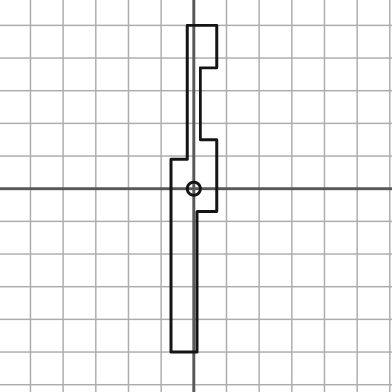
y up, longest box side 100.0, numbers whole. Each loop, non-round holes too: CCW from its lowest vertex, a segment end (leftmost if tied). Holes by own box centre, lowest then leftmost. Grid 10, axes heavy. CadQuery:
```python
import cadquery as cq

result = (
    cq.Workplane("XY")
    .moveTo(-7.0, -50.0)
    .lineTo(1.0, -50.0)
    .lineTo(1.0, -7.0)
    .lineTo(7.0, -7.0)
    .lineTo(7.0, 15.0)
    .lineTo(2.0, 15.0)
    .lineTo(2.0, 37.0)
    .lineTo(7.0, 37.0)
    .lineTo(7.0, 50.0)
    .lineTo(-2.0, 50.0)
    .lineTo(-2.0, 9.0)
    .lineTo(-7.0, 9.0)
    .close()
    .moveTo(0.0, 0.0)
    .circle(2.0)
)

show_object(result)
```